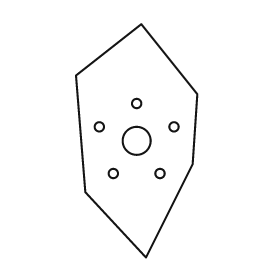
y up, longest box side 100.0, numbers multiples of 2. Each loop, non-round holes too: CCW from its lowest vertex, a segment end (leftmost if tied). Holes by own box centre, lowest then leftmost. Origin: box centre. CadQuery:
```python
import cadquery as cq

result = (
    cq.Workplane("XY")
    .moveTo(4.0, -50.0)
    .lineTo(24.0, -10.0)
    .lineTo(26.0, 20.0)
    .lineTo(2.0, 50.0)
    .lineTo(-26.0, 28.0)
    .lineTo(-22.0, -22.0)
    .close()
    .moveTo(-10.0, -14.0)
    .circle(2.0)
    .moveTo(10.0, -14.0)
    .circle(2.0)
    .moveTo(0.0, 0.0)
    .circle(6.0)
    .moveTo(-16.0, 6.0)
    .circle(2.0)
    .moveTo(16.0, 6.0)
    .circle(2.0)
    .moveTo(0.0, 16.0)
    .circle(2.0)
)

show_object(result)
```